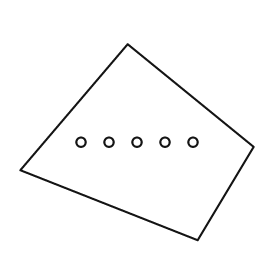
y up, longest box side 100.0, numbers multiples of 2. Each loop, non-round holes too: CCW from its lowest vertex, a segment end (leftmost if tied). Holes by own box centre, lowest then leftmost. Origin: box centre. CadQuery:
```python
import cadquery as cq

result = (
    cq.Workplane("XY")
    .moveTo(26.0, -42.0)
    .lineTo(50.0, -2.0)
    .lineTo(-4.0, 42.0)
    .lineTo(-50.0, -12.0)
    .close()
    .moveTo(-24.0, 0.0)
    .circle(2.0)
    .moveTo(-12.0, 0.0)
    .circle(2.0)
    .moveTo(0.0, 0.0)
    .circle(2.0)
    .moveTo(12.0, 0.0)
    .circle(2.0)
    .moveTo(24.0, 0.0)
    .circle(2.0)
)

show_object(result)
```